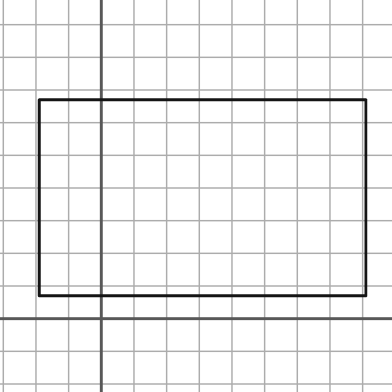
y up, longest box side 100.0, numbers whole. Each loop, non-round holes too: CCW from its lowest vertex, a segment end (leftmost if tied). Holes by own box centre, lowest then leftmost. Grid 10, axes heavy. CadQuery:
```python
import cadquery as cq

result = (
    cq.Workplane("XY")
    .moveTo(-19.0, 7.0)
    .lineTo(81.0, 7.0)
    .lineTo(81.0, 67.0)
    .lineTo(-19.0, 67.0)
    .close()
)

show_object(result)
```